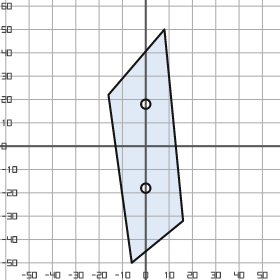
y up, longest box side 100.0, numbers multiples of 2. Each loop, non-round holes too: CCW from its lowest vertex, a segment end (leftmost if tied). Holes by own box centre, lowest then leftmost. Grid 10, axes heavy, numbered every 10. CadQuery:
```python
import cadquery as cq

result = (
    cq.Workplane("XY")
    .moveTo(-6.0, -50.0)
    .lineTo(16.0, -32.0)
    .lineTo(8.0, 50.0)
    .lineTo(-16.0, 22.0)
    .close()
    .moveTo(0.0, -18.0)
    .circle(2.0)
    .moveTo(0.0, 18.0)
    .circle(2.0)
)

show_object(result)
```